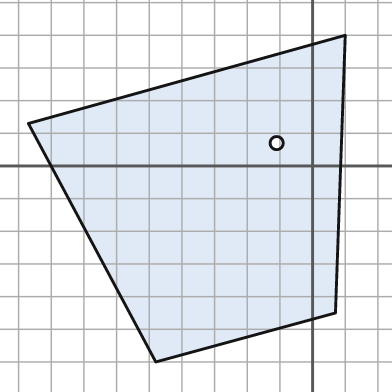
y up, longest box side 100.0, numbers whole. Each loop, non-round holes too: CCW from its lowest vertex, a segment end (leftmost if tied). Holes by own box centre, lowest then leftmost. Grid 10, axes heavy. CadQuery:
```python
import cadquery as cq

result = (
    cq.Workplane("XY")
    .moveTo(-48.0, -60.0)
    .lineTo(7.0, -45.0)
    .lineTo(10.0, 40.0)
    .lineTo(-87.0, 13.0)
    .close()
    .moveTo(-11.0, 7.0)
    .circle(2.0)
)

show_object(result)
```